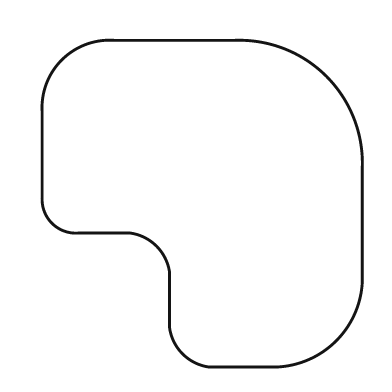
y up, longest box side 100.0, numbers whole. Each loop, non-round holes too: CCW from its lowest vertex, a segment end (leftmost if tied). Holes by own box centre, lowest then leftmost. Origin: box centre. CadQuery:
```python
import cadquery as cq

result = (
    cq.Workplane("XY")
    .moveTo(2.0, -50.0)
    .lineTo(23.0, -50.0)
    .threePointArc((41.0, -42.0), (49.0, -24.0))
    .lineTo(49.0, 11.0)
    .threePointArc((38.0, 39.0), (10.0, 50.0))
    .lineTo(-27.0, 50.0)
    .threePointArc((-43.0, 44.0), (-49.0, 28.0))
    .lineTo(-49.0, 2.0)
    .threePointArc((-46.0, -6.0), (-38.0, -9.0))
    .lineTo(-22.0, -9.0)
    .threePointArc((-14.0, -13.0), (-10.0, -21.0))
    .lineTo(-10.0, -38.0)
    .threePointArc((-6.0, -46.0), (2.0, -50.0))
    .close()
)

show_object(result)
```